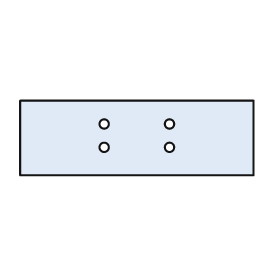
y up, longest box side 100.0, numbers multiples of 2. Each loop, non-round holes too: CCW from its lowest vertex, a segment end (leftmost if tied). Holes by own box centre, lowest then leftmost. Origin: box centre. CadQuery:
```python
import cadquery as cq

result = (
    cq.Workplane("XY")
    .moveTo(-50.0, -16.0)
    .lineTo(50.0, -16.0)
    .lineTo(50.0, 16.0)
    .lineTo(-50.0, 16.0)
    .close()
    .moveTo(-14.0, -4.0)
    .circle(2.0)
    .moveTo(14.0, -4.0)
    .circle(2.0)
    .moveTo(-14.0, 6.0)
    .circle(2.0)
    .moveTo(14.0, 6.0)
    .circle(2.0)
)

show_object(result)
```